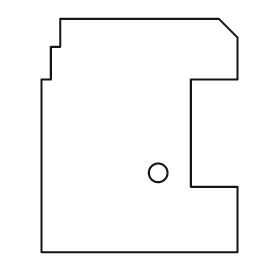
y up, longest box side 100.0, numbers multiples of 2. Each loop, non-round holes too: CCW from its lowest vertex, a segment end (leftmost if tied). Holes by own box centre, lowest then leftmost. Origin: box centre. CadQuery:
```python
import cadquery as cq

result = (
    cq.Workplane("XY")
    .moveTo(-42.0, -50.0)
    .lineTo(42.0, -50.0)
    .lineTo(42.0, -22.0)
    .lineTo(22.0, -22.0)
    .lineTo(22.0, 24.0)
    .lineTo(42.0, 24.0)
    .lineTo(42.0, 42.0)
    .lineTo(34.0, 50.0)
    .lineTo(-34.0, 50.0)
    .lineTo(-34.0, 38.0)
    .lineTo(-38.0, 38.0)
    .lineTo(-38.0, 24.0)
    .lineTo(-42.0, 24.0)
    .close()
    .moveTo(8.0, -16.0)
    .circle(4.0)
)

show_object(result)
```